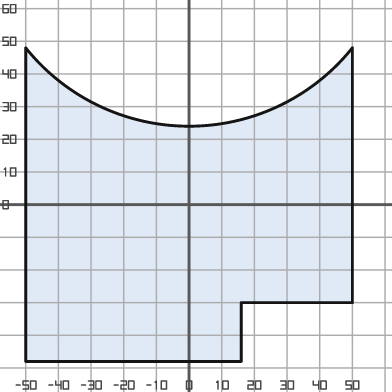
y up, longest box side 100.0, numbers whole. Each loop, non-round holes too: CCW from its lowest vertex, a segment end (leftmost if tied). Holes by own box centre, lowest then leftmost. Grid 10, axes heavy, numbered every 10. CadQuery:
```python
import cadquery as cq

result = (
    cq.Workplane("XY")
    .moveTo(-50.0, -48.0)
    .lineTo(16.0, -48.0)
    .lineTo(16.0, -30.0)
    .lineTo(50.0, -30.0)
    .lineTo(50.0, 48.0)
    .threePointArc((0.0, 24.0), (-50.0, 48.0))
    .close()
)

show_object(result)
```